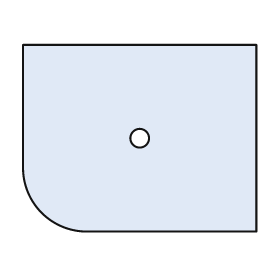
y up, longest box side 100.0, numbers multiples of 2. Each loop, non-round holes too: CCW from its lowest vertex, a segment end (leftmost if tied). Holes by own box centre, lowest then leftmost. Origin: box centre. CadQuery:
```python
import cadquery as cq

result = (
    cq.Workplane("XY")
    .moveTo(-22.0, -40.0)
    .lineTo(50.0, -40.0)
    .lineTo(50.0, 40.0)
    .lineTo(-50.0, 40.0)
    .lineTo(-50.0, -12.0)
    .threePointArc((-42.0, -32.0), (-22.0, -40.0))
    .close()
    .moveTo(0.0, 0.0)
    .circle(4.0)
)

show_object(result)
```